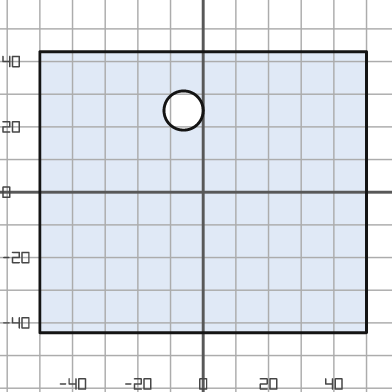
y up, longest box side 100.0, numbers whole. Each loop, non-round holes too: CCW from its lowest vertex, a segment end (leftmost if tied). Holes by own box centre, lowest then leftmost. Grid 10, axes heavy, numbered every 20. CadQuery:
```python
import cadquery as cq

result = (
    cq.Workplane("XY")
    .moveTo(-50.0, -43.0)
    .lineTo(50.0, -43.0)
    .lineTo(50.0, 43.0)
    .lineTo(-50.0, 43.0)
    .close()
    .moveTo(-6.0, 25.0)
    .circle(6.0)
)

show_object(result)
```